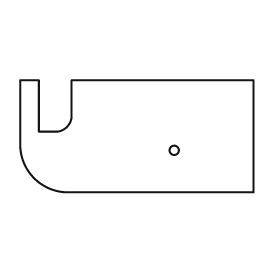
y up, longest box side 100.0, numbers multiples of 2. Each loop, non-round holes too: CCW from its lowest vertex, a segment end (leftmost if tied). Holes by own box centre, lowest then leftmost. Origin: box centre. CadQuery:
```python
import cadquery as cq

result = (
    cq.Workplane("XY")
    .moveTo(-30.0, -24.0)
    .lineTo(50.0, -24.0)
    .lineTo(50.0, 24.0)
    .lineTo(-28.0, 24.0)
    .lineTo(-28.0, 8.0)
    .threePointArc((-30.0, 4.0), (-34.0, 2.0))
    .lineTo(-42.0, 2.0)
    .lineTo(-42.0, 24.0)
    .lineTo(-50.0, 24.0)
    .lineTo(-50.0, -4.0)
    .threePointArc((-44.0, -18.0), (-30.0, -24.0))
    .close()
    .moveTo(16.0, -6.0)
    .circle(2.0)
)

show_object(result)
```